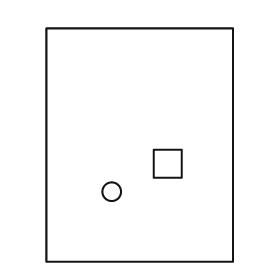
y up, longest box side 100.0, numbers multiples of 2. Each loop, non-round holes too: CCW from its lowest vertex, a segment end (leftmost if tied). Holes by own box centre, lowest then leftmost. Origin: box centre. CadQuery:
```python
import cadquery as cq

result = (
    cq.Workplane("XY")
    .moveTo(-40.0, -50.0)
    .lineTo(40.0, -50.0)
    .lineTo(40.0, 50.0)
    .lineTo(-40.0, 50.0)
    .close()
    .moveTo(-12.0, -20.0)
    .circle(4.0)
    .moveTo(6.0, -14.0)
    .lineTo(18.0, -14.0)
    .lineTo(18.0, -2.0)
    .lineTo(6.0, -2.0)
    .close()
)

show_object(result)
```